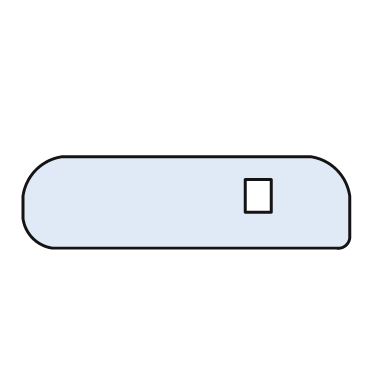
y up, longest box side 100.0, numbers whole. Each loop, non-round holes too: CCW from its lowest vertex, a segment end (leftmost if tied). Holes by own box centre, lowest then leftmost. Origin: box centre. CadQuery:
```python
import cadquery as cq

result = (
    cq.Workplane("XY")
    .moveTo(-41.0, -14.0)
    .lineTo(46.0, -14.0)
    .threePointArc((49.0, -13.0), (50.0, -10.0))
    .lineTo(50.0, 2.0)
    .threePointArc((46.0, 10.0), (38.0, 14.0))
    .lineTo(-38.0, 14.0)
    .threePointArc((-46.0, 10.0), (-50.0, 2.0))
    .lineTo(-50.0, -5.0)
    .threePointArc((-47.0, -11.0), (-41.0, -14.0))
    .close()
    .moveTo(18.0, -3.0)
    .lineTo(26.0, -3.0)
    .lineTo(26.0, 7.0)
    .lineTo(18.0, 7.0)
    .close()
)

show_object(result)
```